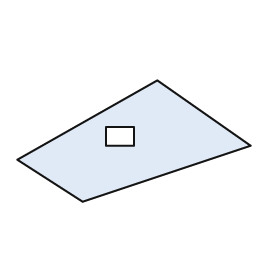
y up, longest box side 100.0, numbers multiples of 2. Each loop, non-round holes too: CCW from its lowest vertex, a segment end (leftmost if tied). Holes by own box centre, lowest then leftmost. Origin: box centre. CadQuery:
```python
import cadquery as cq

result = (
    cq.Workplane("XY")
    .moveTo(-22.0, -26.0)
    .lineTo(50.0, -2.0)
    .lineTo(10.0, 26.0)
    .lineTo(-50.0, -8.0)
    .close()
    .moveTo(-12.0, -2.0)
    .lineTo(0.0, -2.0)
    .lineTo(0.0, 6.0)
    .lineTo(-12.0, 6.0)
    .close()
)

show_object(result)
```